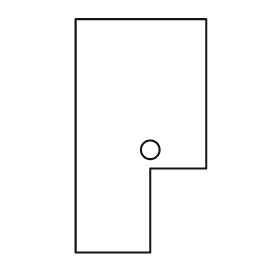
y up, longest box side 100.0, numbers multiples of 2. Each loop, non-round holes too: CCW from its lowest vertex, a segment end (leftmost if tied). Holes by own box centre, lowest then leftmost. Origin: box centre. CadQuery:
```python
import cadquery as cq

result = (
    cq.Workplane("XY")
    .moveTo(-28.0, -50.0)
    .lineTo(4.0, -50.0)
    .lineTo(4.0, -14.0)
    .lineTo(28.0, -14.0)
    .lineTo(28.0, 50.0)
    .lineTo(-28.0, 50.0)
    .close()
    .moveTo(4.0, -6.0)
    .circle(4.0)
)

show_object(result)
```